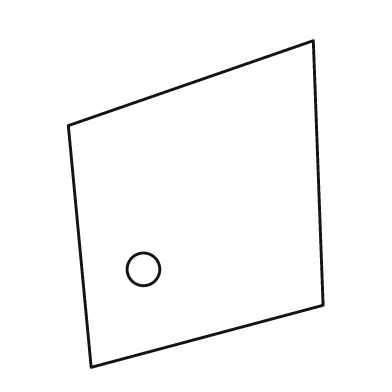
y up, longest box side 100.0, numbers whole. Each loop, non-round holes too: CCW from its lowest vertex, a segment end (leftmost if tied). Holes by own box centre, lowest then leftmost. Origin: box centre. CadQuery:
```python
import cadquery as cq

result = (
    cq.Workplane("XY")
    .moveTo(-32.0, -50.0)
    .lineTo(39.0, -31.0)
    .lineTo(36.0, 50.0)
    .lineTo(-39.0, 24.0)
    .close()
    .moveTo(-16.0, -20.0)
    .circle(5.0)
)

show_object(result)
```